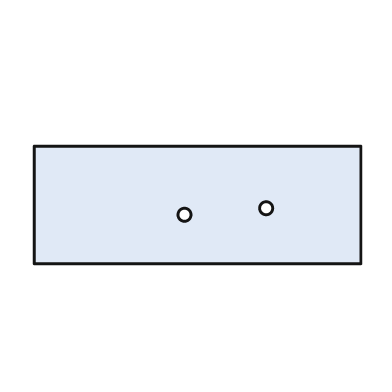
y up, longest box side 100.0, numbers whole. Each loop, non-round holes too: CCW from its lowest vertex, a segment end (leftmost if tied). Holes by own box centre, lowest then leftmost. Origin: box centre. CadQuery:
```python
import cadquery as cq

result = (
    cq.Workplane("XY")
    .moveTo(-50.0, -18.0)
    .lineTo(50.0, -18.0)
    .lineTo(50.0, 18.0)
    .lineTo(-50.0, 18.0)
    .close()
    .moveTo(-4.0, -3.0)
    .circle(2.0)
    .moveTo(21.0, -1.0)
    .circle(2.0)
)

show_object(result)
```